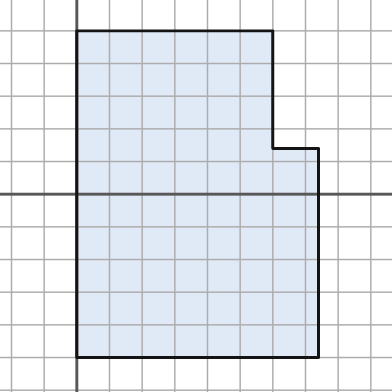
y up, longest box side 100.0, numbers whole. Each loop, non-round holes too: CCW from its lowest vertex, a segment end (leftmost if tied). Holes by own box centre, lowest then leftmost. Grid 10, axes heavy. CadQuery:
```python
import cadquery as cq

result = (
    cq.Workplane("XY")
    .moveTo(0.0, -50.0)
    .lineTo(74.0, -50.0)
    .lineTo(74.0, 14.0)
    .lineTo(60.0, 14.0)
    .lineTo(60.0, 50.0)
    .lineTo(0.0, 50.0)
    .close()
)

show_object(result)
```